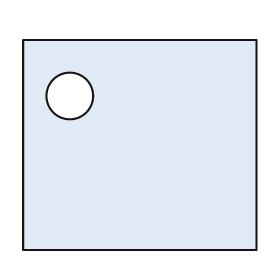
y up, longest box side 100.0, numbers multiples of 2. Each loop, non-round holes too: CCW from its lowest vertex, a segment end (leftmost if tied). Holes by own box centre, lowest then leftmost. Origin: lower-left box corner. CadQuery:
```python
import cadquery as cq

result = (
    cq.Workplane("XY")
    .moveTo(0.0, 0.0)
    .lineTo(100.0, 0.0)
    .lineTo(100.0, 90.0)
    .lineTo(0.0, 90.0)
    .close()
    .moveTo(20.0, 66.0)
    .circle(10.0)
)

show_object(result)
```